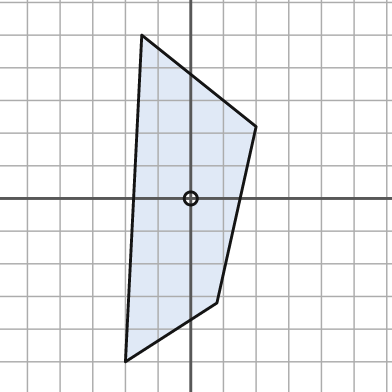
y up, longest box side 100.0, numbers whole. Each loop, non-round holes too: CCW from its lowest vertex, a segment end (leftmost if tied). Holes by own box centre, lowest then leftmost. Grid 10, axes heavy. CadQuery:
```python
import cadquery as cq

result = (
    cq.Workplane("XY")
    .moveTo(-20.0, -50.0)
    .lineTo(8.0, -32.0)
    .lineTo(20.0, 22.0)
    .lineTo(-15.0, 50.0)
    .close()
    .moveTo(0.0, 0.0)
    .circle(2.0)
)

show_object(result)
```